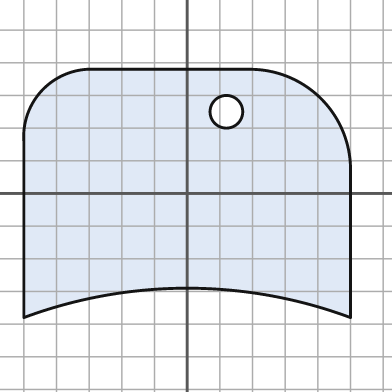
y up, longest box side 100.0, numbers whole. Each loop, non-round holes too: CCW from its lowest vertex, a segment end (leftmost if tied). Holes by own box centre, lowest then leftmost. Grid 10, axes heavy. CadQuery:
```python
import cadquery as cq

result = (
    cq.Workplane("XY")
    .moveTo(-50.0, -38.0)
    .threePointArc((0.0, -29.0), (50.0, -38.0))
    .lineTo(50.0, 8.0)
    .threePointArc((41.0, 29.0), (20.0, 38.0))
    .lineTo(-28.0, 38.0)
    .threePointArc((-44.0, 32.0), (-50.0, 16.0))
    .close()
    .moveTo(12.0, 25.0)
    .circle(5.0)
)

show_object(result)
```